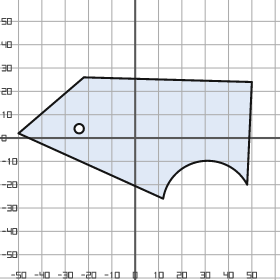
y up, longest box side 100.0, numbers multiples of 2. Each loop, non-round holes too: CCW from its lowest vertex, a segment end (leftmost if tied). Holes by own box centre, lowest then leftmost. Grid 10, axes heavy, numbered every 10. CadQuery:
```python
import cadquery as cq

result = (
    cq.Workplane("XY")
    .moveTo(12.0, -26.0)
    .threePointArc((28.0, -10.0), (48.0, -20.0))
    .lineTo(50.0, 24.0)
    .lineTo(-22.0, 26.0)
    .lineTo(-50.0, 2.0)
    .close()
    .moveTo(-24.0, 4.0)
    .circle(2.0)
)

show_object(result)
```